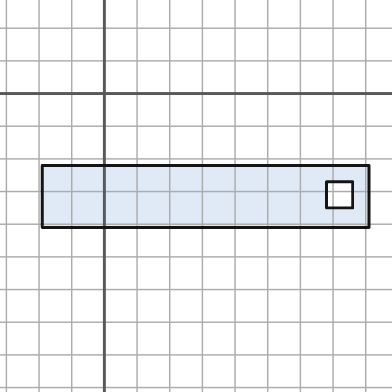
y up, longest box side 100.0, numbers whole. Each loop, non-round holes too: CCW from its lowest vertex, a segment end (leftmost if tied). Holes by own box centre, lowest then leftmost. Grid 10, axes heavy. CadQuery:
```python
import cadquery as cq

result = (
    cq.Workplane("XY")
    .moveTo(-19.0, -41.0)
    .lineTo(81.0, -41.0)
    .lineTo(81.0, -22.0)
    .lineTo(-19.0, -22.0)
    .close()
    .moveTo(68.0, -35.0)
    .lineTo(76.0, -35.0)
    .lineTo(76.0, -27.0)
    .lineTo(68.0, -27.0)
    .close()
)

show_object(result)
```